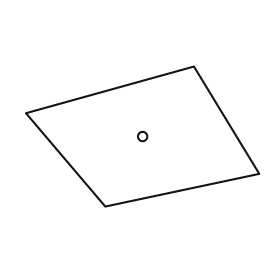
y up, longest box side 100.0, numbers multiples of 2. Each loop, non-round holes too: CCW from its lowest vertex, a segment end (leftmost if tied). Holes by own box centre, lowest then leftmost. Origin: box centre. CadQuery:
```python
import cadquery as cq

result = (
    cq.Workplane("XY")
    .moveTo(-16.0, -30.0)
    .lineTo(50.0, -16.0)
    .lineTo(22.0, 30.0)
    .lineTo(-50.0, 10.0)
    .close()
    .moveTo(0.0, 0.0)
    .circle(2.0)
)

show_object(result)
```